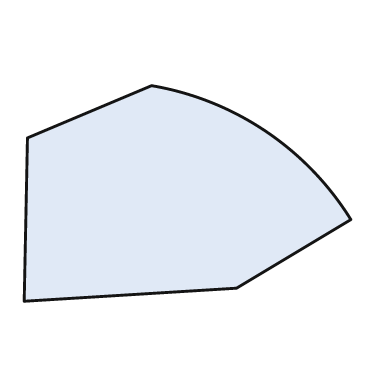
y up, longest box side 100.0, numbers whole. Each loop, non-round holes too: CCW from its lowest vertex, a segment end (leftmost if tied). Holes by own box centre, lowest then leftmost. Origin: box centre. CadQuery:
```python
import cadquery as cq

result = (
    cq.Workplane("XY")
    .moveTo(-50.0, -33.0)
    .lineTo(15.0, -29.0)
    .lineTo(50.0, -8.0)
    .threePointArc((24.0, 19.0), (-11.0, 33.0))
    .lineTo(-49.0, 17.0)
    .close()
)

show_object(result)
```